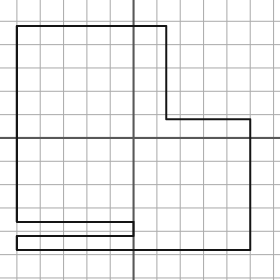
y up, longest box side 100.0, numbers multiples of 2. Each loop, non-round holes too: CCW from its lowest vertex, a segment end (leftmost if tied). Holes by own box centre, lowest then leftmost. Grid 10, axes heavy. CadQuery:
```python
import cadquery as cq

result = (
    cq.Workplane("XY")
    .moveTo(-50.0, -48.0)
    .lineTo(50.0, -48.0)
    .lineTo(50.0, 8.0)
    .lineTo(14.0, 8.0)
    .lineTo(14.0, 48.0)
    .lineTo(-50.0, 48.0)
    .lineTo(-50.0, -36.0)
    .lineTo(0.0, -36.0)
    .lineTo(0.0, -42.0)
    .lineTo(-50.0, -42.0)
    .close()
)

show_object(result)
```